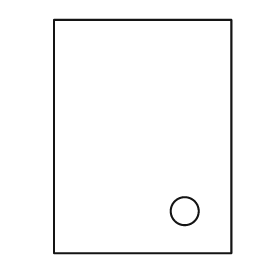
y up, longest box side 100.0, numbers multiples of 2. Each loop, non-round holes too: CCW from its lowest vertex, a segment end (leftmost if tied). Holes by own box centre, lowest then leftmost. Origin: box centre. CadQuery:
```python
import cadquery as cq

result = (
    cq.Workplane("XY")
    .moveTo(-38.0, -50.0)
    .lineTo(38.0, -50.0)
    .lineTo(38.0, 50.0)
    .lineTo(-38.0, 50.0)
    .close()
    .moveTo(18.0, -32.0)
    .circle(6.0)
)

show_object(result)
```